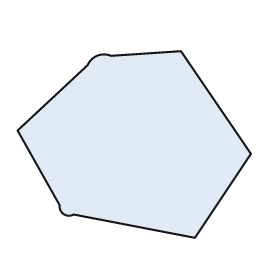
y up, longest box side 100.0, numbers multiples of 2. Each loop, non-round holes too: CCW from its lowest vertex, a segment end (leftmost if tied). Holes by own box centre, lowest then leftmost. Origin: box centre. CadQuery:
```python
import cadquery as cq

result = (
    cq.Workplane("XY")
    .moveTo(26.0, -40.0)
    .lineTo(50.0, -4.0)
    .lineTo(20.0, 40.0)
    .lineTo(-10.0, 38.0)
    .threePointArc((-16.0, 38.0), (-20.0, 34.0))
    .lineTo(-50.0, 6.0)
    .lineTo(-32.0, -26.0)
    .threePointArc((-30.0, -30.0), (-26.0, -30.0))
    .close()
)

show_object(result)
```